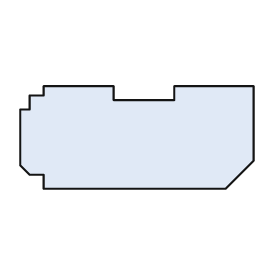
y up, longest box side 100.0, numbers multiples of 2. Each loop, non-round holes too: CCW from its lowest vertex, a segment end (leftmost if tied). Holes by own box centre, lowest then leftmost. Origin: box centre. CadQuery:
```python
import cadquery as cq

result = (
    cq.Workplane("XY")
    .moveTo(-40.0, -22.0)
    .lineTo(38.0, -22.0)
    .lineTo(50.0, -10.0)
    .lineTo(50.0, 22.0)
    .lineTo(16.0, 22.0)
    .lineTo(16.0, 16.0)
    .lineTo(-10.0, 16.0)
    .lineTo(-10.0, 22.0)
    .lineTo(-40.0, 22.0)
    .lineTo(-40.0, 18.0)
    .lineTo(-46.0, 18.0)
    .lineTo(-46.0, 12.0)
    .lineTo(-50.0, 12.0)
    .lineTo(-50.0, -12.0)
    .lineTo(-46.0, -16.0)
    .lineTo(-40.0, -16.0)
    .close()
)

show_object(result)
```